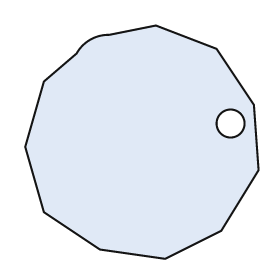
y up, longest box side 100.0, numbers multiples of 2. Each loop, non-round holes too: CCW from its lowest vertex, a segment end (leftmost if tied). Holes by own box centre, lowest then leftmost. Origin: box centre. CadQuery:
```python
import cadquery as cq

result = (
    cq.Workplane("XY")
    .moveTo(10.0, -50.0)
    .lineTo(34.0, -38.0)
    .lineTo(50.0, -12.0)
    .lineTo(48.0, 16.0)
    .lineTo(32.0, 40.0)
    .lineTo(6.0, 50.0)
    .lineTo(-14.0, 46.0)
    .threePointArc((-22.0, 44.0), (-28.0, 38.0))
    .lineTo(-42.0, 26.0)
    .lineTo(-50.0, -2.0)
    .lineTo(-42.0, -30.0)
    .lineTo(-18.0, -46.0)
    .close()
    .moveTo(38.0, 8.0)
    .circle(6.0)
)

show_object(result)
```